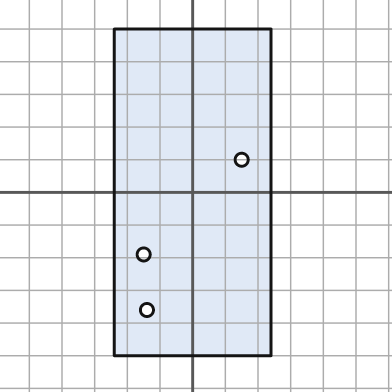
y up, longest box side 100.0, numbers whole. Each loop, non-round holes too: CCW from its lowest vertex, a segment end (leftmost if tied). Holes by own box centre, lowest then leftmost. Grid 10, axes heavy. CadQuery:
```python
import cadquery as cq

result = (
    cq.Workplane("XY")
    .moveTo(-24.0, -50.0)
    .lineTo(24.0, -50.0)
    .lineTo(24.0, 50.0)
    .lineTo(-24.0, 50.0)
    .close()
    .moveTo(-14.0, -36.0)
    .circle(2.0)
    .moveTo(-15.0, -19.0)
    .circle(2.0)
    .moveTo(15.0, 10.0)
    .circle(2.0)
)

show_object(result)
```